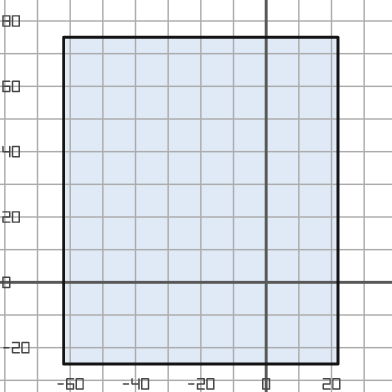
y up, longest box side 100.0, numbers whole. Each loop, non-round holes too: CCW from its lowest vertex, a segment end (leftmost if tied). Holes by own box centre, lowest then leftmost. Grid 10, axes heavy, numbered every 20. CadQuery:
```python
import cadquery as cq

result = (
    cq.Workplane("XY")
    .moveTo(-62.0, -25.0)
    .lineTo(22.0, -25.0)
    .lineTo(22.0, 75.0)
    .lineTo(-62.0, 75.0)
    .close()
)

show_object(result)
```